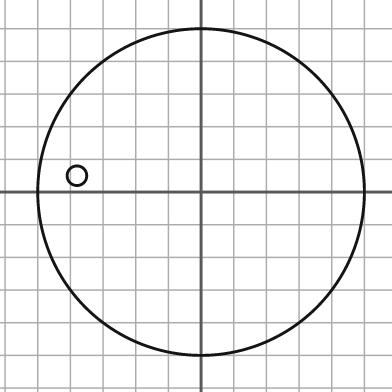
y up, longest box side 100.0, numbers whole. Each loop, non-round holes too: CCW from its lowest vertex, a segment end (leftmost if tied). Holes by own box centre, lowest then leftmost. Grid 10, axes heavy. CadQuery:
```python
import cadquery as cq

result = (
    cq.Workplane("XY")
    .moveTo(0.0, 0.0)
    .circle(50.0)
    .moveTo(-38.0, 5.0)
    .circle(3.0)
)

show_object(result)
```